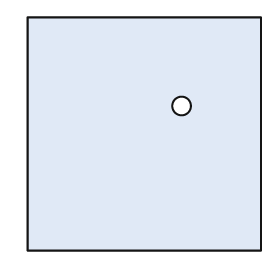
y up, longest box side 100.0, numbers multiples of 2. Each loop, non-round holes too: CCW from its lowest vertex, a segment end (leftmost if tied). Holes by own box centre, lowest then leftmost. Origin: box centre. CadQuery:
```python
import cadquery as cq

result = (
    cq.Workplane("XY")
    .moveTo(-50.0, -50.0)
    .lineTo(50.0, -50.0)
    .lineTo(50.0, 50.0)
    .lineTo(-50.0, 50.0)
    .close()
    .moveTo(16.0, 12.0)
    .circle(4.0)
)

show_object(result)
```